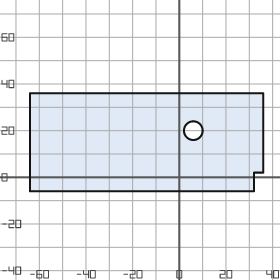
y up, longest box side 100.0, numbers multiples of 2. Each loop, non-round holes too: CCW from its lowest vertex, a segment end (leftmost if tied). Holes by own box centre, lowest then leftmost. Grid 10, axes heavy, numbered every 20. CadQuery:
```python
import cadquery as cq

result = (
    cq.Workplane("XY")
    .moveTo(-64.0, -6.0)
    .lineTo(32.0, -6.0)
    .lineTo(32.0, 2.0)
    .lineTo(36.0, 2.0)
    .lineTo(36.0, 36.0)
    .lineTo(-64.0, 36.0)
    .close()
    .moveTo(6.0, 20.0)
    .circle(4.0)
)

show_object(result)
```